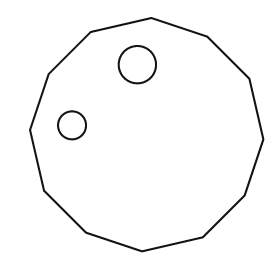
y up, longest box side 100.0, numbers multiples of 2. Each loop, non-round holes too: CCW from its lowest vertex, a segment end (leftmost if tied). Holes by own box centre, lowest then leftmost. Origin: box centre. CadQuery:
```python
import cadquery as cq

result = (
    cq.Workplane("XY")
    .moveTo(-2.0, -50.0)
    .lineTo(24.0, -44.0)
    .lineTo(42.0, -26.0)
    .lineTo(50.0, -2.0)
    .lineTo(44.0, 24.0)
    .lineTo(26.0, 42.0)
    .lineTo(2.0, 50.0)
    .lineTo(-24.0, 44.0)
    .lineTo(-42.0, 26.0)
    .lineTo(-50.0, 2.0)
    .lineTo(-44.0, -24.0)
    .lineTo(-26.0, -42.0)
    .close()
    .moveTo(-32.0, 4.0)
    .circle(6.0)
    .moveTo(-4.0, 30.0)
    .circle(8.0)
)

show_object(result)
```